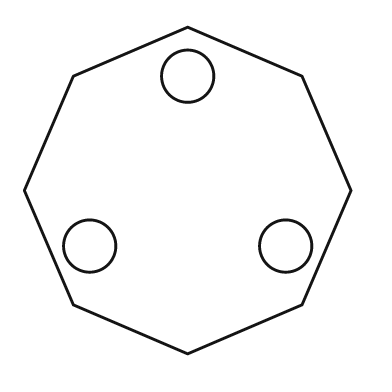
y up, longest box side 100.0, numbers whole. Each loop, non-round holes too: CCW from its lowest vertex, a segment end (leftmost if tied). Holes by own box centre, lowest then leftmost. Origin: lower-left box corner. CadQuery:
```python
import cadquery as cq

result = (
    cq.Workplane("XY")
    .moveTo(50.0, 0.0)
    .lineTo(85.0, 15.0)
    .lineTo(100.0, 50.0)
    .lineTo(85.0, 85.0)
    .lineTo(50.0, 100.0)
    .lineTo(15.0, 85.0)
    .lineTo(0.0, 50.0)
    .lineTo(15.0, 15.0)
    .close()
    .moveTo(20.0, 33.0)
    .circle(8.0)
    .moveTo(80.0, 33.0)
    .circle(8.0)
    .moveTo(50.0, 85.0)
    .circle(8.0)
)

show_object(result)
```